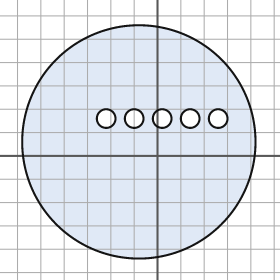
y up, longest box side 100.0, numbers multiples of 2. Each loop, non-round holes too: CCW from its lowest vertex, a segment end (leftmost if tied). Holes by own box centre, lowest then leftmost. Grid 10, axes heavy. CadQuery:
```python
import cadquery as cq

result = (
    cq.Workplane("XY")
    .moveTo(-8.0, 6.0)
    .circle(50.0)
    .moveTo(-22.0, 16.0)
    .circle(4.0)
    .moveTo(-10.0, 16.0)
    .circle(4.0)
    .moveTo(2.0, 16.0)
    .circle(4.0)
    .moveTo(14.0, 16.0)
    .circle(4.0)
    .moveTo(26.0, 16.0)
    .circle(4.0)
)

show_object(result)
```